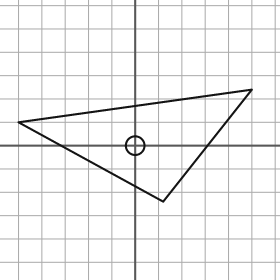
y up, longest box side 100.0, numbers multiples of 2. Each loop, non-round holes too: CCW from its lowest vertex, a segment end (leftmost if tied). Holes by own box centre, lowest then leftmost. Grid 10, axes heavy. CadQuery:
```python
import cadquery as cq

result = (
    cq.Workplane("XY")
    .moveTo(12.0, -24.0)
    .lineTo(50.0, 24.0)
    .lineTo(-50.0, 10.0)
    .close()
    .moveTo(0.0, 0.0)
    .circle(4.0)
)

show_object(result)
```